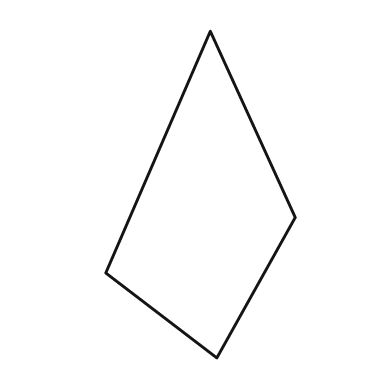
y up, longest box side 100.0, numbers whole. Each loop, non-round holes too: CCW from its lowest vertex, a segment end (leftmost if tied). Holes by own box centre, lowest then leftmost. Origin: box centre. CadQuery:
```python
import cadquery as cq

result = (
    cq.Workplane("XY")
    .moveTo(5.0, -50.0)
    .lineTo(29.0, -7.0)
    .lineTo(3.0, 50.0)
    .lineTo(-29.0, -24.0)
    .close()
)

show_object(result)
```